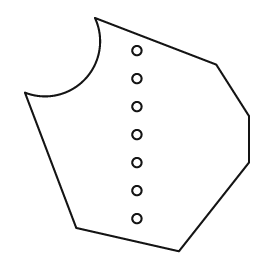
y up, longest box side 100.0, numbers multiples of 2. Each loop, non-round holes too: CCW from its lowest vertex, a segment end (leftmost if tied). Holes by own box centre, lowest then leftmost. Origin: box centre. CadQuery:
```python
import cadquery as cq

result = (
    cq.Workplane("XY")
    .moveTo(18.0, -50.0)
    .lineTo(48.0, -12.0)
    .lineTo(48.0, 8.0)
    .lineTo(34.0, 30.0)
    .lineTo(-18.0, 50.0)
    .threePointArc((-22.0, 24.0), (-48.0, 18.0))
    .lineTo(-26.0, -40.0)
    .close()
    .moveTo(0.0, -36.0)
    .circle(2.0)
    .moveTo(0.0, -24.0)
    .circle(2.0)
    .moveTo(0.0, -12.0)
    .circle(2.0)
    .moveTo(0.0, 0.0)
    .circle(2.0)
    .moveTo(0.0, 12.0)
    .circle(2.0)
    .moveTo(0.0, 24.0)
    .circle(2.0)
    .moveTo(0.0, 36.0)
    .circle(2.0)
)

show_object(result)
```